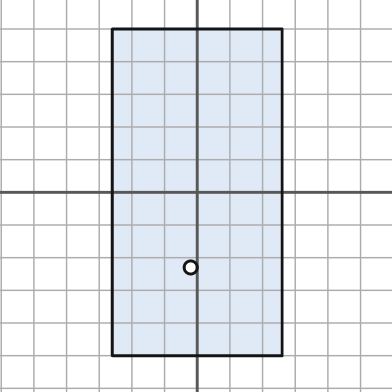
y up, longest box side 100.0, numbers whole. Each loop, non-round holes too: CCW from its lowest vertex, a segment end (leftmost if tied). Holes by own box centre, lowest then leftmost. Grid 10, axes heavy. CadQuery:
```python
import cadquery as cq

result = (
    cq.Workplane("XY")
    .moveTo(-26.0, -50.0)
    .lineTo(26.0, -50.0)
    .lineTo(26.0, 50.0)
    .lineTo(-26.0, 50.0)
    .close()
    .moveTo(-2.0, -23.0)
    .circle(2.0)
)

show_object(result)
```